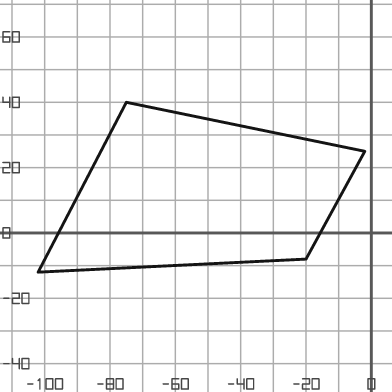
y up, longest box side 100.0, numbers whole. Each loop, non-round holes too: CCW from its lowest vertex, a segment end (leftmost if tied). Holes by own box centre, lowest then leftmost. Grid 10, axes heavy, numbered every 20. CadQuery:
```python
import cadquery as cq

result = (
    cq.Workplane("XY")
    .moveTo(-102.0, -12.0)
    .lineTo(-20.0, -8.0)
    .lineTo(-2.0, 25.0)
    .lineTo(-75.0, 40.0)
    .close()
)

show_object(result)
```